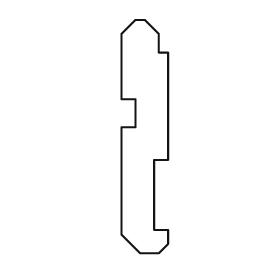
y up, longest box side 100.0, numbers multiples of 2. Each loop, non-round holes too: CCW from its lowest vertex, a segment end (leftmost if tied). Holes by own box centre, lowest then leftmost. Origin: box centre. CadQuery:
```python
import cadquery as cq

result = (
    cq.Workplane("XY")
    .moveTo(-2.0, -50.0)
    .lineTo(6.0, -50.0)
    .lineTo(10.0, -46.0)
    .lineTo(10.0, -40.0)
    .lineTo(4.0, -40.0)
    .lineTo(4.0, -10.0)
    .lineTo(10.0, -10.0)
    .lineTo(10.0, 36.0)
    .lineTo(6.0, 36.0)
    .lineTo(6.0, 44.0)
    .lineTo(0.0, 50.0)
    .lineTo(-4.0, 50.0)
    .lineTo(-10.0, 44.0)
    .lineTo(-10.0, 16.0)
    .lineTo(-4.0, 16.0)
    .lineTo(-4.0, 4.0)
    .lineTo(-10.0, 4.0)
    .lineTo(-10.0, -42.0)
    .close()
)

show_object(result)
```